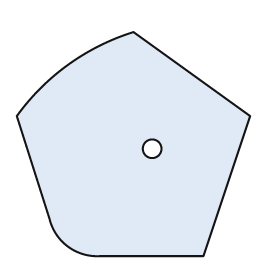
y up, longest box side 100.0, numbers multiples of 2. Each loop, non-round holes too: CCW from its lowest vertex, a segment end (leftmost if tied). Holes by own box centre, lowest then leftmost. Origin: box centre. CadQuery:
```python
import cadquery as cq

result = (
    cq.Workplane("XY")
    .moveTo(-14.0, -48.0)
    .lineTo(30.0, -48.0)
    .lineTo(50.0, 12.0)
    .lineTo(0.0, 48.0)
    .threePointArc((-28.0, 34.0), (-50.0, 12.0))
    .lineTo(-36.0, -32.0)
    .threePointArc((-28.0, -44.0), (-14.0, -48.0))
    .close()
    .moveTo(8.0, -2.0)
    .circle(4.0)
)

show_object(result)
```